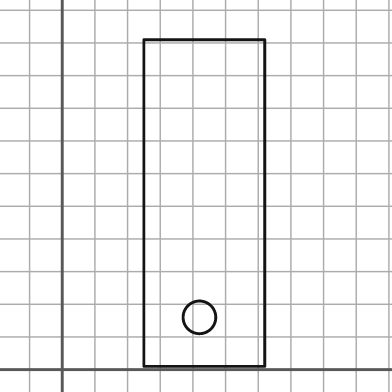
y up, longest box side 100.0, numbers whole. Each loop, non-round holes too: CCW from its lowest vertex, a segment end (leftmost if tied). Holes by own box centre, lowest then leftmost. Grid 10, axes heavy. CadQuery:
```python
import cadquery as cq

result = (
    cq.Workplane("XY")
    .moveTo(25.0, 1.0)
    .lineTo(62.0, 1.0)
    .lineTo(62.0, 101.0)
    .lineTo(25.0, 101.0)
    .close()
    .moveTo(42.0, 16.0)
    .circle(5.0)
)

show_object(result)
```